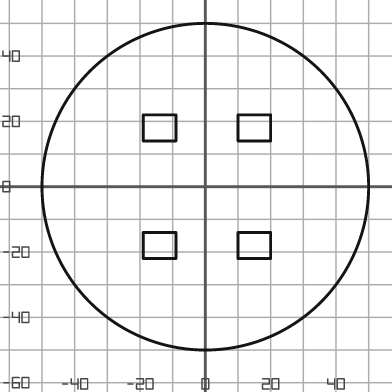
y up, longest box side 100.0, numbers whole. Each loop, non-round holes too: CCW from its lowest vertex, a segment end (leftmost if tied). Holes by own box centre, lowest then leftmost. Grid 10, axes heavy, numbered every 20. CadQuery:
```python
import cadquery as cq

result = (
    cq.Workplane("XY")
    .moveTo(0.0, 0.0)
    .circle(50.0)
    .moveTo(-19.0, -22.0)
    .lineTo(-9.0, -22.0)
    .lineTo(-9.0, -14.0)
    .lineTo(-19.0, -14.0)
    .close()
    .moveTo(10.0, -22.0)
    .lineTo(20.0, -22.0)
    .lineTo(20.0, -14.0)
    .lineTo(10.0, -14.0)
    .close()
    .moveTo(-19.0, 14.0)
    .lineTo(-9.0, 14.0)
    .lineTo(-9.0, 22.0)
    .lineTo(-19.0, 22.0)
    .close()
    .moveTo(10.0, 14.0)
    .lineTo(20.0, 14.0)
    .lineTo(20.0, 22.0)
    .lineTo(10.0, 22.0)
    .close()
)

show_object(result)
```